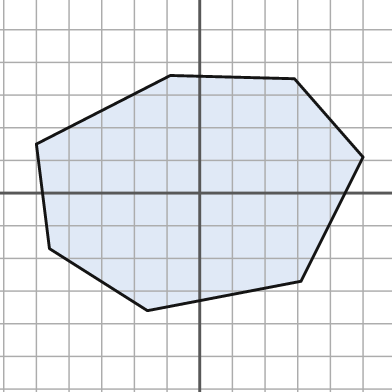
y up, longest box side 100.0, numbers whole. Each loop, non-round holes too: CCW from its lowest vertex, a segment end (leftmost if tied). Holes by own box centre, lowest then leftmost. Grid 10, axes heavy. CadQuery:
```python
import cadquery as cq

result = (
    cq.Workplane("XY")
    .moveTo(-16.0, -36.0)
    .lineTo(31.0, -27.0)
    .lineTo(50.0, 11.0)
    .lineTo(29.0, 35.0)
    .lineTo(-9.0, 36.0)
    .lineTo(-50.0, 15.0)
    .lineTo(-46.0, -17.0)
    .close()
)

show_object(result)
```